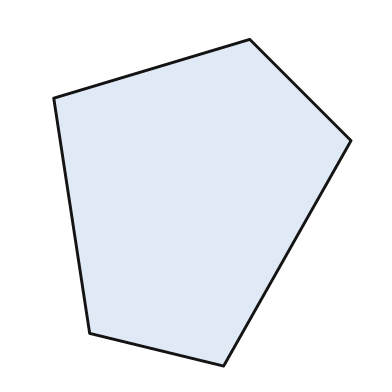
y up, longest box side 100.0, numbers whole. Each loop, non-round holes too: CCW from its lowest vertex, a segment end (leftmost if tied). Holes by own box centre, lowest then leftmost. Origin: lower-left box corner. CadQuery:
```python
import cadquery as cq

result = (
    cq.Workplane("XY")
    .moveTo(52.0, 0.0)
    .lineTo(91.0, 69.0)
    .lineTo(60.0, 100.0)
    .lineTo(0.0, 82.0)
    .lineTo(11.0, 10.0)
    .close()
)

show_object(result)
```